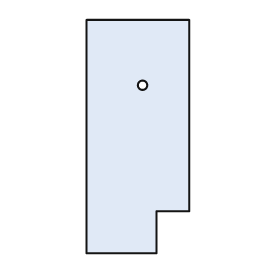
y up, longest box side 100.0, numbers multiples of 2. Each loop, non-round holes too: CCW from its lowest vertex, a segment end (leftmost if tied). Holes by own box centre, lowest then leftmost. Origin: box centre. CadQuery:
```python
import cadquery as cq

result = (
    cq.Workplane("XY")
    .moveTo(-22.0, -50.0)
    .lineTo(8.0, -50.0)
    .lineTo(8.0, -32.0)
    .lineTo(22.0, -32.0)
    .lineTo(22.0, 50.0)
    .lineTo(-22.0, 50.0)
    .close()
    .moveTo(2.0, 22.0)
    .circle(2.0)
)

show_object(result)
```